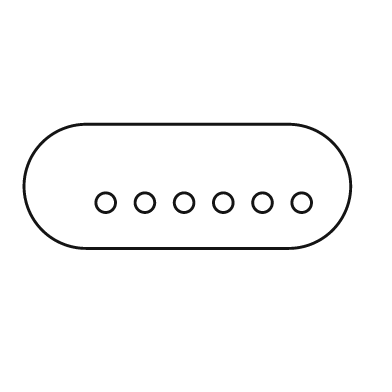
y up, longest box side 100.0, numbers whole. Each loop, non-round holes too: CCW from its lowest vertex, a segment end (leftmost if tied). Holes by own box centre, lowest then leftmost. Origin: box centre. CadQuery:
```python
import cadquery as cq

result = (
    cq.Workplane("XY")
    .moveTo(-31.0, -19.0)
    .lineTo(31.0, -19.0)
    .threePointArc((50.0, 0.0), (31.0, 19.0))
    .lineTo(-31.0, 19.0)
    .threePointArc((-50.0, 0.0), (-31.0, -19.0))
    .close()
    .moveTo(-25.0, -5.0)
    .circle(3.0)
    .moveTo(-13.0, -5.0)
    .circle(3.0)
    .moveTo(-1.0, -5.0)
    .circle(3.0)
    .moveTo(11.0, -5.0)
    .circle(3.0)
    .moveTo(23.0, -5.0)
    .circle(3.0)
    .moveTo(35.0, -5.0)
    .circle(3.0)
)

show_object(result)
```